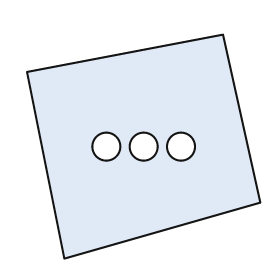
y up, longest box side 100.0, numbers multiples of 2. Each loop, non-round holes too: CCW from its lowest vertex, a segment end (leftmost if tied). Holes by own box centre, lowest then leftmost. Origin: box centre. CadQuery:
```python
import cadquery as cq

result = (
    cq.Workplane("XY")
    .moveTo(-34.0, -48.0)
    .lineTo(50.0, -24.0)
    .lineTo(34.0, 48.0)
    .lineTo(-50.0, 32.0)
    .close()
    .moveTo(-16.0, 0.0)
    .circle(6.0)
    .moveTo(0.0, 0.0)
    .circle(6.0)
    .moveTo(16.0, 0.0)
    .circle(6.0)
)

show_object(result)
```